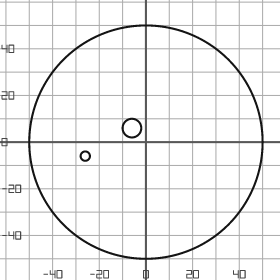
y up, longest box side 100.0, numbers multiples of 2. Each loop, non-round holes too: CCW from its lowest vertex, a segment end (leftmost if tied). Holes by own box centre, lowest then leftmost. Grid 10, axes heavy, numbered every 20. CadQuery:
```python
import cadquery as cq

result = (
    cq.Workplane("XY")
    .moveTo(0.0, 0.0)
    .circle(50.0)
    .moveTo(-26.0, -6.0)
    .circle(2.0)
    .moveTo(-6.0, 6.0)
    .circle(4.0)
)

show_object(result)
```